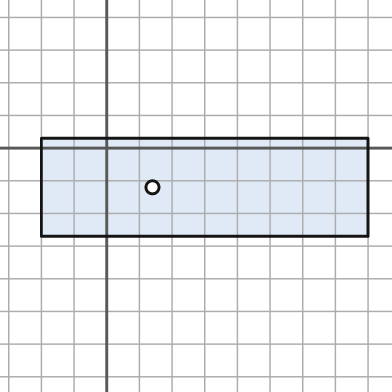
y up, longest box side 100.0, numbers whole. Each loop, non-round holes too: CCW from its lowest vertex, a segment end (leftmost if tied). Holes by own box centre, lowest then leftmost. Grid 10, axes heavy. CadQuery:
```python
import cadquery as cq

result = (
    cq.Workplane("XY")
    .moveTo(-20.0, -27.0)
    .lineTo(80.0, -27.0)
    .lineTo(80.0, 3.0)
    .lineTo(-20.0, 3.0)
    .close()
    .moveTo(14.0, -12.0)
    .circle(2.0)
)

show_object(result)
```